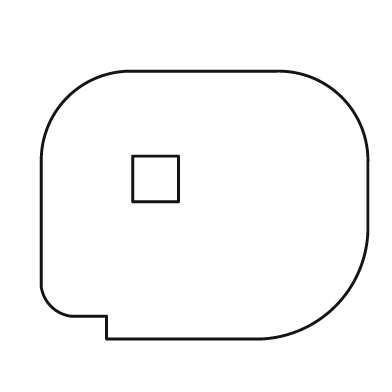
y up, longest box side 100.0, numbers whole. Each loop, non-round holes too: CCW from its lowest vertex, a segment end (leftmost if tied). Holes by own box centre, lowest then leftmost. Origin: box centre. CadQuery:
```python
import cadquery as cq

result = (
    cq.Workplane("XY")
    .moveTo(-30.0, -41.0)
    .lineTo(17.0, -41.0)
    .threePointArc((40.0, -31.0), (50.0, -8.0))
    .lineTo(50.0, 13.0)
    .threePointArc((42.0, 33.0), (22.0, 41.0))
    .lineTo(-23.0, 41.0)
    .threePointArc((-42.0, 33.0), (-50.0, 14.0))
    .lineTo(-50.0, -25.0)
    .threePointArc((-47.0, -31.0), (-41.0, -34.0))
    .lineTo(-30.0, -34.0)
    .close()
    .moveTo(-22.0, 1.0)
    .lineTo(-8.0, 1.0)
    .lineTo(-8.0, 15.0)
    .lineTo(-22.0, 15.0)
    .close()
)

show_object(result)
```